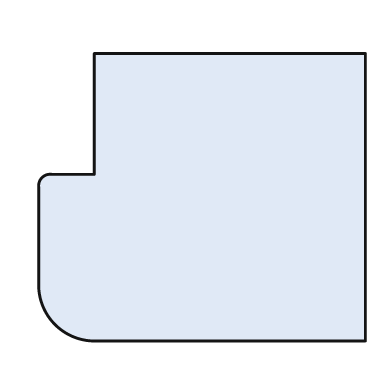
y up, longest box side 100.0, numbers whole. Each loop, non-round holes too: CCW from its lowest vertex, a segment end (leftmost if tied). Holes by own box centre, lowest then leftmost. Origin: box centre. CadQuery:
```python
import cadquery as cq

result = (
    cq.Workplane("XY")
    .moveTo(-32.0, -44.0)
    .lineTo(50.0, -44.0)
    .lineTo(50.0, 44.0)
    .lineTo(-33.0, 44.0)
    .lineTo(-33.0, 7.0)
    .lineTo(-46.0, 7.0)
    .threePointArc((-49.0, 6.0), (-50.0, 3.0))
    .lineTo(-50.0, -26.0)
    .threePointArc((-45.0, -39.0), (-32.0, -44.0))
    .close()
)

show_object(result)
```